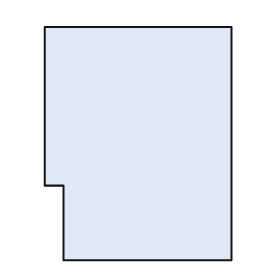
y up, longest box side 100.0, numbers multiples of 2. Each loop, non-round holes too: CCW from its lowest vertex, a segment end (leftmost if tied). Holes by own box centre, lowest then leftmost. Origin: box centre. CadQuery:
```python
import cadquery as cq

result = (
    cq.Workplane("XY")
    .moveTo(-32.0, -50.0)
    .lineTo(40.0, -50.0)
    .lineTo(40.0, 50.0)
    .lineTo(-40.0, 50.0)
    .lineTo(-40.0, -18.0)
    .lineTo(-32.0, -18.0)
    .close()
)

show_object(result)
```